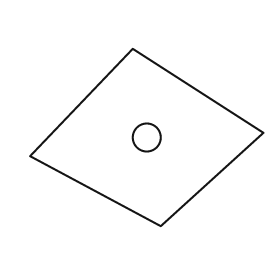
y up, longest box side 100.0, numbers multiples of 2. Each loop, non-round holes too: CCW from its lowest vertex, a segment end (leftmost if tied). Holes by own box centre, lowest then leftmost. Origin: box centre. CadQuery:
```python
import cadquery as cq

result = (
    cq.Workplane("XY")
    .moveTo(6.0, -38.0)
    .lineTo(50.0, 2.0)
    .lineTo(-6.0, 38.0)
    .lineTo(-50.0, -8.0)
    .close()
    .moveTo(0.0, 0.0)
    .circle(6.0)
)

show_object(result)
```